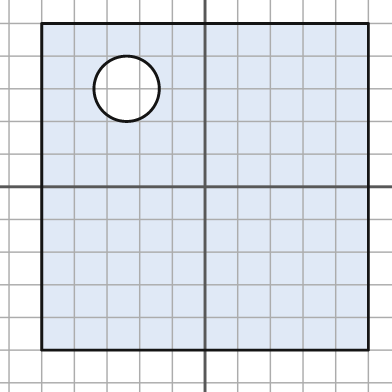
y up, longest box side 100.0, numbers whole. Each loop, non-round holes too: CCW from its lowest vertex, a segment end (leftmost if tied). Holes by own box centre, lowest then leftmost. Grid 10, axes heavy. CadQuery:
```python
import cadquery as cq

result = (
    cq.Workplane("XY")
    .moveTo(-50.0, -50.0)
    .lineTo(50.0, -50.0)
    .lineTo(50.0, 50.0)
    .lineTo(-50.0, 50.0)
    .close()
    .moveTo(-24.0, 30.0)
    .circle(10.0)
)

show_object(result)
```